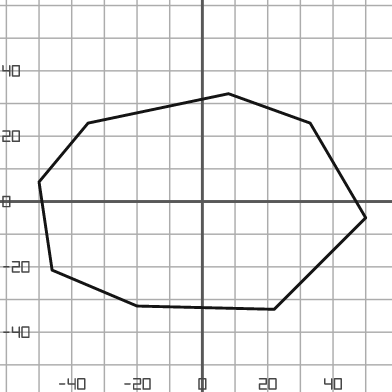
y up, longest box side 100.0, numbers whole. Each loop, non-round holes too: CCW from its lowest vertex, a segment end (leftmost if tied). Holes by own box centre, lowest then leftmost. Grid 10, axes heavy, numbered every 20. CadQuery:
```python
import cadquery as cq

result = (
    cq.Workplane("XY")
    .moveTo(22.0, -33.0)
    .lineTo(50.0, -5.0)
    .lineTo(33.0, 24.0)
    .lineTo(8.0, 33.0)
    .lineTo(-35.0, 24.0)
    .lineTo(-50.0, 6.0)
    .lineTo(-46.0, -21.0)
    .lineTo(-20.0, -32.0)
    .close()
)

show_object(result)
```